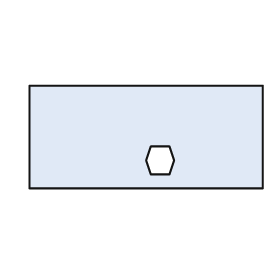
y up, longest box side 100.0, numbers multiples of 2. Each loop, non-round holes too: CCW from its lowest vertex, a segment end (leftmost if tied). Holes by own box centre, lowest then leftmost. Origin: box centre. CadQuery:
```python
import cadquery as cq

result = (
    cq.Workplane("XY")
    .moveTo(-50.0, -22.0)
    .lineTo(50.0, -22.0)
    .lineTo(50.0, 22.0)
    .lineTo(-50.0, 22.0)
    .close()
    .moveTo(2.0, -16.0)
    .lineTo(10.0, -16.0)
    .lineTo(12.0, -10.0)
    .lineTo(10.0, -4.0)
    .lineTo(2.0, -4.0)
    .lineTo(0.0, -10.0)
    .close()
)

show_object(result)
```